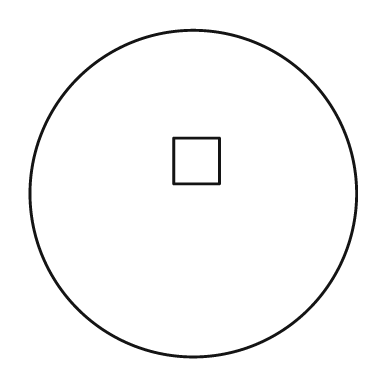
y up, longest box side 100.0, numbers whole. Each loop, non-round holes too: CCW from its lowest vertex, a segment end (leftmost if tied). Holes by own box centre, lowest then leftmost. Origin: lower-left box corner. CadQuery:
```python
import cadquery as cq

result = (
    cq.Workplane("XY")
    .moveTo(50.0, 50.0)
    .circle(50.0)
    .moveTo(44.0, 53.0)
    .lineTo(58.0, 53.0)
    .lineTo(58.0, 67.0)
    .lineTo(44.0, 67.0)
    .close()
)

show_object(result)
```